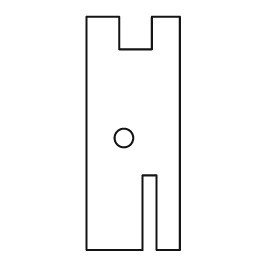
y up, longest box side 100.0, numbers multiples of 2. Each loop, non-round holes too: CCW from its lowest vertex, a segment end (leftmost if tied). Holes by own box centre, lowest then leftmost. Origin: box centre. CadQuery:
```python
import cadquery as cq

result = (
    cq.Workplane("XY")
    .moveTo(-20.0, -50.0)
    .lineTo(4.0, -50.0)
    .lineTo(4.0, -18.0)
    .lineTo(10.0, -18.0)
    .lineTo(10.0, -50.0)
    .lineTo(20.0, -50.0)
    .lineTo(20.0, 50.0)
    .lineTo(8.0, 50.0)
    .lineTo(8.0, 36.0)
    .lineTo(-6.0, 36.0)
    .lineTo(-6.0, 50.0)
    .lineTo(-20.0, 50.0)
    .close()
    .moveTo(-4.0, -2.0)
    .circle(4.0)
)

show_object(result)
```